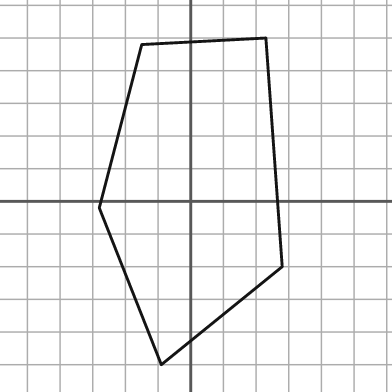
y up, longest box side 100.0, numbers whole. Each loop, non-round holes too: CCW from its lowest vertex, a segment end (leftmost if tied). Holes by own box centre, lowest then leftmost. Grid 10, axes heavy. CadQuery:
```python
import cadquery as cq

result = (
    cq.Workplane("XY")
    .moveTo(-9.0, -50.0)
    .lineTo(28.0, -20.0)
    .lineTo(23.0, 50.0)
    .lineTo(-15.0, 48.0)
    .lineTo(-28.0, -2.0)
    .close()
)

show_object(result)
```